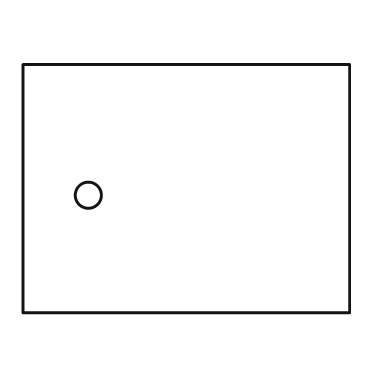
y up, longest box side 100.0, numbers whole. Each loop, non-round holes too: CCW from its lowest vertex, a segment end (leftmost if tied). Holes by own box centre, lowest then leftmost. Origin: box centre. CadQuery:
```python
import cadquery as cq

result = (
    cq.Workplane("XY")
    .moveTo(-50.0, -38.0)
    .lineTo(50.0, -38.0)
    .lineTo(50.0, 38.0)
    .lineTo(-50.0, 38.0)
    .close()
    .moveTo(-30.0, -2.0)
    .circle(4.0)
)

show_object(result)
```